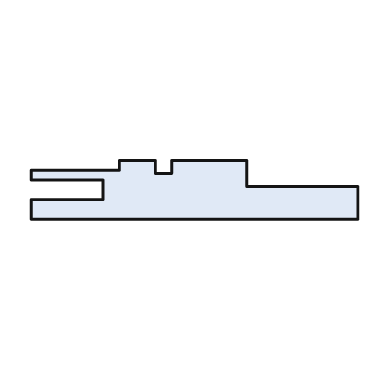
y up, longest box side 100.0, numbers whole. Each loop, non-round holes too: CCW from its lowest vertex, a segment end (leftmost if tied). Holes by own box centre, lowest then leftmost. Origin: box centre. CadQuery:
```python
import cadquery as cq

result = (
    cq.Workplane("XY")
    .moveTo(-50.0, -9.0)
    .lineTo(50.0, -9.0)
    .lineTo(50.0, 1.0)
    .lineTo(16.0, 1.0)
    .lineTo(16.0, 9.0)
    .lineTo(-7.0, 9.0)
    .lineTo(-7.0, 5.0)
    .lineTo(-12.0, 5.0)
    .lineTo(-12.0, 9.0)
    .lineTo(-23.0, 9.0)
    .lineTo(-23.0, 6.0)
    .lineTo(-50.0, 6.0)
    .lineTo(-50.0, 3.0)
    .lineTo(-28.0, 3.0)
    .lineTo(-28.0, -3.0)
    .lineTo(-50.0, -3.0)
    .close()
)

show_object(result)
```